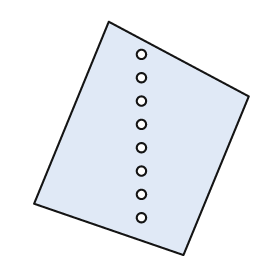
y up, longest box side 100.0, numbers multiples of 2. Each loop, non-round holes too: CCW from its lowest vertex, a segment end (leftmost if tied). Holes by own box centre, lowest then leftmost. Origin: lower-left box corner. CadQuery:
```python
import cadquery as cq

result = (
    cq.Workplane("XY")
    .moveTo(64.0, 0.0)
    .lineTo(92.0, 68.0)
    .lineTo(32.0, 100.0)
    .lineTo(0.0, 22.0)
    .close()
    .moveTo(46.0, 16.0)
    .circle(2.0)
    .moveTo(46.0, 26.0)
    .circle(2.0)
    .moveTo(46.0, 36.0)
    .circle(2.0)
    .moveTo(46.0, 46.0)
    .circle(2.0)
    .moveTo(46.0, 56.0)
    .circle(2.0)
    .moveTo(46.0, 66.0)
    .circle(2.0)
    .moveTo(46.0, 76.0)
    .circle(2.0)
    .moveTo(46.0, 86.0)
    .circle(2.0)
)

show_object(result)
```